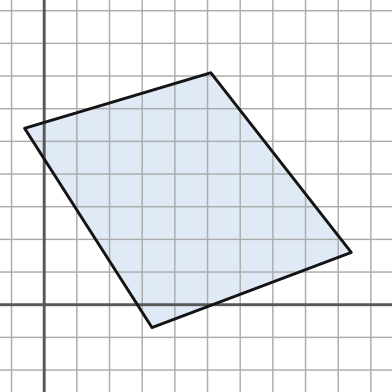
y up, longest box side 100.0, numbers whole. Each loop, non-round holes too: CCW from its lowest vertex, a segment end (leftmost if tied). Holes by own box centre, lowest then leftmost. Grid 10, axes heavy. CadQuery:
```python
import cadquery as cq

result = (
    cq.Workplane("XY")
    .moveTo(33.0, -7.0)
    .lineTo(94.0, 16.0)
    .lineTo(51.0, 71.0)
    .lineTo(-6.0, 54.0)
    .close()
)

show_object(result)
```